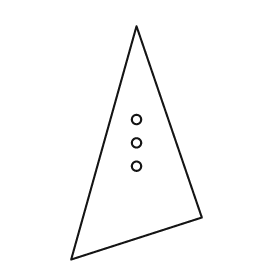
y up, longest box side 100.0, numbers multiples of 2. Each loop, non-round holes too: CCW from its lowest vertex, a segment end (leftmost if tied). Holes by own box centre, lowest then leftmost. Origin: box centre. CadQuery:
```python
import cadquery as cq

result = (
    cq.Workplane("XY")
    .moveTo(-28.0, -50.0)
    .lineTo(28.0, -32.0)
    .lineTo(0.0, 50.0)
    .close()
    .moveTo(0.0, -10.0)
    .circle(2.0)
    .moveTo(0.0, 0.0)
    .circle(2.0)
    .moveTo(0.0, 10.0)
    .circle(2.0)
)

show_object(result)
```